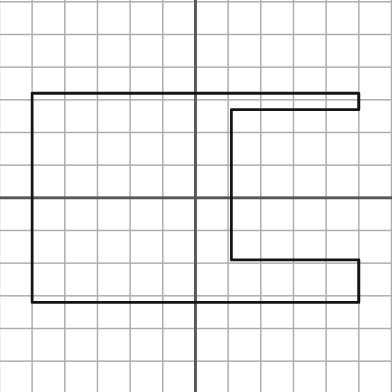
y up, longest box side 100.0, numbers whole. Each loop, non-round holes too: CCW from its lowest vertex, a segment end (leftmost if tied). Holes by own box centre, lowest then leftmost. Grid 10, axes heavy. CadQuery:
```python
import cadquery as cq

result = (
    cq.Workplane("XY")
    .moveTo(-50.0, -32.0)
    .lineTo(50.0, -32.0)
    .lineTo(50.0, -19.0)
    .lineTo(11.0, -19.0)
    .lineTo(11.0, 27.0)
    .lineTo(50.0, 27.0)
    .lineTo(50.0, 32.0)
    .lineTo(-50.0, 32.0)
    .close()
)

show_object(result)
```